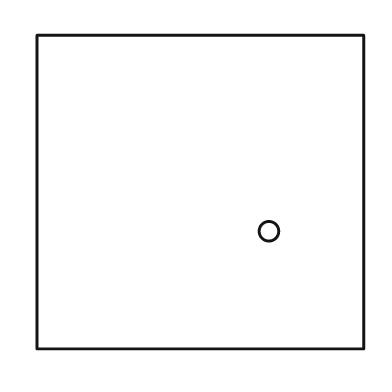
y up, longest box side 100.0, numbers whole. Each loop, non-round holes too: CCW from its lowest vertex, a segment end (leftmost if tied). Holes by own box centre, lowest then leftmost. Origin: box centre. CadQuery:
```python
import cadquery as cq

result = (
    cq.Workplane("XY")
    .moveTo(-50.0, -48.0)
    .lineTo(50.0, -48.0)
    .lineTo(50.0, 48.0)
    .lineTo(-50.0, 48.0)
    .close()
    .moveTo(21.0, -12.0)
    .circle(3.0)
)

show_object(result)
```